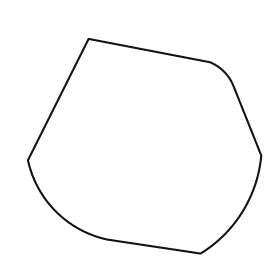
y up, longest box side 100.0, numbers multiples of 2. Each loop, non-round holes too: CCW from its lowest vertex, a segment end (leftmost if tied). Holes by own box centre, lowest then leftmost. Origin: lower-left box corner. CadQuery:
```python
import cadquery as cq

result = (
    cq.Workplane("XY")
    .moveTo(74.0, 0.0)
    .threePointArc((92.0, 18.0), (100.0, 42.0))
    .lineTo(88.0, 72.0)
    .threePointArc((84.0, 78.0), (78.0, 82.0))
    .lineTo(26.0, 92.0)
    .lineTo(0.0, 40.0)
    .threePointArc((12.0, 18.0), (34.0, 6.0))
    .close()
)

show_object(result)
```